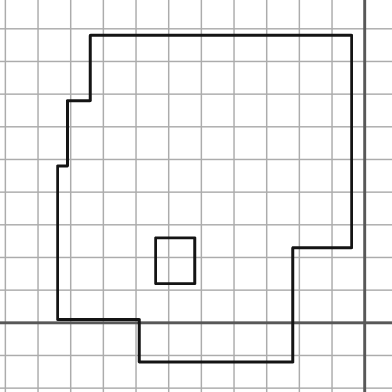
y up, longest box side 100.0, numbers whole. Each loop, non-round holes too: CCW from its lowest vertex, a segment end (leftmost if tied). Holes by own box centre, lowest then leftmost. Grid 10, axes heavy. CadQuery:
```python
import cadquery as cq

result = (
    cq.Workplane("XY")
    .moveTo(-69.0, -12.0)
    .lineTo(-22.0, -12.0)
    .lineTo(-22.0, 23.0)
    .lineTo(-4.0, 23.0)
    .lineTo(-4.0, 88.0)
    .lineTo(-84.0, 88.0)
    .lineTo(-84.0, 68.0)
    .lineTo(-91.0, 68.0)
    .lineTo(-91.0, 48.0)
    .lineTo(-94.0, 48.0)
    .lineTo(-94.0, 1.0)
    .lineTo(-69.0, 1.0)
    .close()
    .moveTo(-64.0, 12.0)
    .lineTo(-52.0, 12.0)
    .lineTo(-52.0, 26.0)
    .lineTo(-64.0, 26.0)
    .close()
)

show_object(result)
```